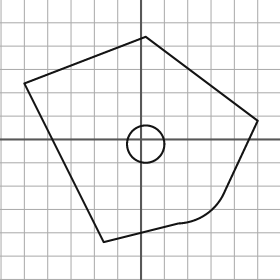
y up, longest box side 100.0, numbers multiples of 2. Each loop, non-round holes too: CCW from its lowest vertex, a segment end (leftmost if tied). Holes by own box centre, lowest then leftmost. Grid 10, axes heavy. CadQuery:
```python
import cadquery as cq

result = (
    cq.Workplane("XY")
    .moveTo(-16.0, -44.0)
    .lineTo(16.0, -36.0)
    .threePointArc((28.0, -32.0), (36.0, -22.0))
    .lineTo(50.0, 8.0)
    .lineTo(2.0, 44.0)
    .lineTo(-50.0, 24.0)
    .close()
    .moveTo(2.0, -2.0)
    .circle(8.0)
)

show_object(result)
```